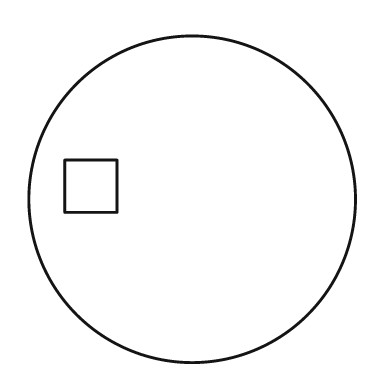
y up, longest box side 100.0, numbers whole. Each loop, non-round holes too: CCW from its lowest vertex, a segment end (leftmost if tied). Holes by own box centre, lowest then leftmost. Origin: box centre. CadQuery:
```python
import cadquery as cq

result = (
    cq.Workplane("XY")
    .moveTo(0.0, 0.0)
    .circle(50.0)
    .moveTo(-39.0, -4.0)
    .lineTo(-23.0, -4.0)
    .lineTo(-23.0, 12.0)
    .lineTo(-39.0, 12.0)
    .close()
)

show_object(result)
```